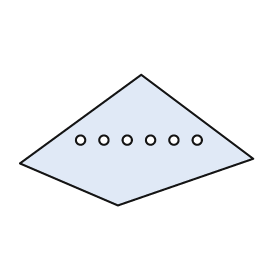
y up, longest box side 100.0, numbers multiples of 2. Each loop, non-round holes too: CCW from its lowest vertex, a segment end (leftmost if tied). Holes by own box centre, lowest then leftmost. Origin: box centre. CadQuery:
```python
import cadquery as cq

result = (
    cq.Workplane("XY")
    .moveTo(-8.0, -28.0)
    .lineTo(50.0, -8.0)
    .lineTo(2.0, 28.0)
    .lineTo(-50.0, -10.0)
    .close()
    .moveTo(-24.0, 0.0)
    .circle(2.0)
    .moveTo(-14.0, 0.0)
    .circle(2.0)
    .moveTo(-4.0, 0.0)
    .circle(2.0)
    .moveTo(6.0, 0.0)
    .circle(2.0)
    .moveTo(16.0, 0.0)
    .circle(2.0)
    .moveTo(26.0, 0.0)
    .circle(2.0)
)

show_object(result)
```